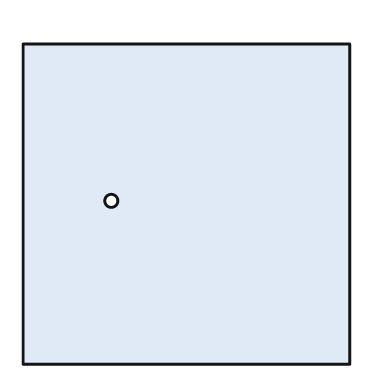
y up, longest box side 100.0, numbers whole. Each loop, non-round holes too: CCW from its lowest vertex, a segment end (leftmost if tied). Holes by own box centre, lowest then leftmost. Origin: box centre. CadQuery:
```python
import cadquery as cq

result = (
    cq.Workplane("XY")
    .moveTo(-50.0, -49.0)
    .lineTo(50.0, -49.0)
    .lineTo(50.0, 49.0)
    .lineTo(-50.0, 49.0)
    .close()
    .moveTo(-23.0, 1.0)
    .circle(2.0)
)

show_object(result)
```